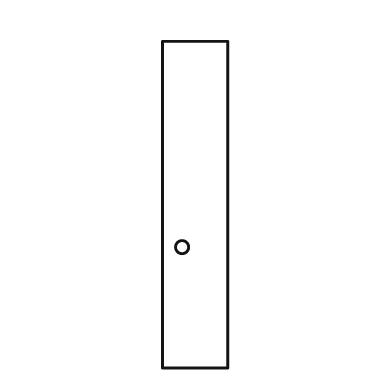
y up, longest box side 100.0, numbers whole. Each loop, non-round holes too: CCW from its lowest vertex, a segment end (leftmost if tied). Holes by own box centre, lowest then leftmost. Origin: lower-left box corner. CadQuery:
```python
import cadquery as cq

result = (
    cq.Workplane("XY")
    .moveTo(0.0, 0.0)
    .lineTo(20.0, 0.0)
    .lineTo(20.0, 100.0)
    .lineTo(0.0, 100.0)
    .close()
    .moveTo(6.0, 37.0)
    .circle(2.0)
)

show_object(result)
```